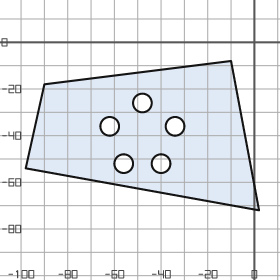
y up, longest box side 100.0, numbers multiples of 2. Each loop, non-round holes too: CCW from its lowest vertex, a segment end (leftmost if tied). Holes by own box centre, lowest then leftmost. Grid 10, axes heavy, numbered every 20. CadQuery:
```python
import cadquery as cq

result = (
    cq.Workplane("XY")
    .moveTo(2.0, -72.0)
    .lineTo(-10.0, -8.0)
    .lineTo(-90.0, -18.0)
    .lineTo(-98.0, -54.0)
    .close()
    .moveTo(-56.0, -52.0)
    .circle(4.0)
    .moveTo(-40.0, -52.0)
    .circle(4.0)
    .moveTo(-62.0, -36.0)
    .circle(4.0)
    .moveTo(-34.0, -36.0)
    .circle(4.0)
    .moveTo(-48.0, -26.0)
    .circle(4.0)
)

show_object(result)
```